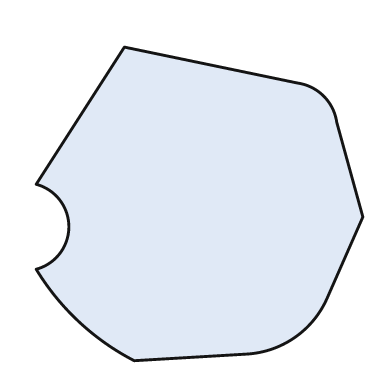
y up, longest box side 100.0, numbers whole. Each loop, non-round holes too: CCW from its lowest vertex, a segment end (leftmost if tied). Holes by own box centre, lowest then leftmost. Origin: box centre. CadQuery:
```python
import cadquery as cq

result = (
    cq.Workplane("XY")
    .moveTo(-20.0, -48.0)
    .lineTo(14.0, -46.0)
    .threePointArc((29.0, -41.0), (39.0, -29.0))
    .lineTo(50.0, -4.0)
    .lineTo(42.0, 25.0)
    .threePointArc((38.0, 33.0), (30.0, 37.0))
    .lineTo(-23.0, 48.0)
    .lineTo(-50.0, 6.0)
    .threePointArc((-40.0, -7.0), (-50.0, -20.0))
    .threePointArc((-37.0, -36.0), (-20.0, -48.0))
    .close()
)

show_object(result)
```